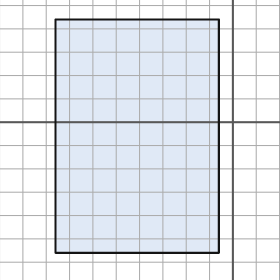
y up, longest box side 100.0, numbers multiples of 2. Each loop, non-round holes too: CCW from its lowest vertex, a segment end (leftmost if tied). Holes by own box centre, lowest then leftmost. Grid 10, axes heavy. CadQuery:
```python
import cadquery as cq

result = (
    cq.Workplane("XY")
    .moveTo(-76.0, -56.0)
    .lineTo(-6.0, -56.0)
    .lineTo(-6.0, 44.0)
    .lineTo(-76.0, 44.0)
    .close()
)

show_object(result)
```